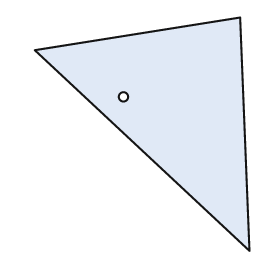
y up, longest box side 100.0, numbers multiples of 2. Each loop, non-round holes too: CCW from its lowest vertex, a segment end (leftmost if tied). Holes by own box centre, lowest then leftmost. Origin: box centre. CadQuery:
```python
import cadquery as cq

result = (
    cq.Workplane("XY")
    .moveTo(46.0, -50.0)
    .lineTo(42.0, 50.0)
    .lineTo(-46.0, 36.0)
    .close()
    .moveTo(-8.0, 16.0)
    .circle(2.0)
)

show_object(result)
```